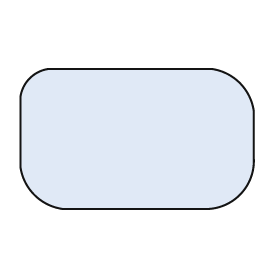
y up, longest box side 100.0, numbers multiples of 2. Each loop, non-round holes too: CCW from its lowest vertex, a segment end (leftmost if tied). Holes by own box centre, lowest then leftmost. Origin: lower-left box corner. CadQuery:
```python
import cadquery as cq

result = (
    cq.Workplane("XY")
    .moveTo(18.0, 0.0)
    .lineTo(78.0, 0.0)
    .threePointArc((94.0, 6.0), (100.0, 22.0))
    .lineTo(100.0, 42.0)
    .threePointArc((94.0, 54.0), (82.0, 60.0))
    .lineTo(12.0, 60.0)
    .threePointArc((4.0, 56.0), (0.0, 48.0))
    .lineTo(0.0, 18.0)
    .threePointArc((6.0, 6.0), (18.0, 0.0))
    .close()
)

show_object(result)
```